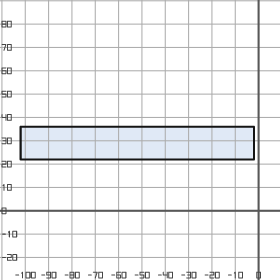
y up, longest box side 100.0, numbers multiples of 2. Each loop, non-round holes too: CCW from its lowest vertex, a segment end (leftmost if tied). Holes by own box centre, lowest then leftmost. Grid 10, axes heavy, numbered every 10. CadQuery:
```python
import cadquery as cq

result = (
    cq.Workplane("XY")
    .moveTo(-102.0, 22.0)
    .lineTo(-2.0, 22.0)
    .lineTo(-2.0, 36.0)
    .lineTo(-102.0, 36.0)
    .close()
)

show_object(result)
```